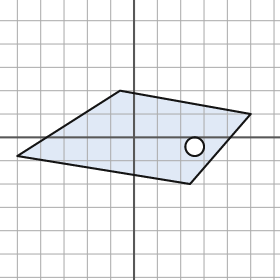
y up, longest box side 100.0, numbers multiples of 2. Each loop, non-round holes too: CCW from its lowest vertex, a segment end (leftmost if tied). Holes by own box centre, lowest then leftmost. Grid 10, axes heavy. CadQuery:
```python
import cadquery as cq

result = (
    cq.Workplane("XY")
    .moveTo(24.0, -20.0)
    .lineTo(50.0, 10.0)
    .lineTo(-6.0, 20.0)
    .lineTo(-50.0, -8.0)
    .close()
    .moveTo(26.0, -4.0)
    .circle(4.0)
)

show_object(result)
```